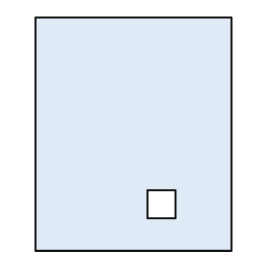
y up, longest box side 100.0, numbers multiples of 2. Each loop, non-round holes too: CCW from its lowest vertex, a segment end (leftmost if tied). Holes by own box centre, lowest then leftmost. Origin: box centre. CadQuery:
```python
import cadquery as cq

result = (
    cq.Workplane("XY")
    .moveTo(-42.0, -50.0)
    .lineTo(42.0, -50.0)
    .lineTo(42.0, 50.0)
    .lineTo(-42.0, 50.0)
    .close()
    .moveTo(6.0, -36.0)
    .lineTo(18.0, -36.0)
    .lineTo(18.0, -24.0)
    .lineTo(6.0, -24.0)
    .close()
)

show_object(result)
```